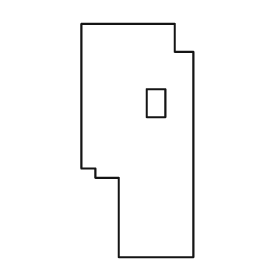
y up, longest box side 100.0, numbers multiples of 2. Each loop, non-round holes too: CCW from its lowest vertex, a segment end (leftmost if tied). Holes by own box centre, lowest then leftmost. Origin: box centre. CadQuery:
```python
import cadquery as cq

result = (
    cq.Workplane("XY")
    .moveTo(-8.0, -50.0)
    .lineTo(24.0, -50.0)
    .lineTo(24.0, 38.0)
    .lineTo(16.0, 38.0)
    .lineTo(16.0, 50.0)
    .lineTo(-24.0, 50.0)
    .lineTo(-24.0, -12.0)
    .lineTo(-18.0, -12.0)
    .lineTo(-18.0, -16.0)
    .lineTo(-8.0, -16.0)
    .close()
    .moveTo(4.0, 10.0)
    .lineTo(12.0, 10.0)
    .lineTo(12.0, 22.0)
    .lineTo(4.0, 22.0)
    .close()
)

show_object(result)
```